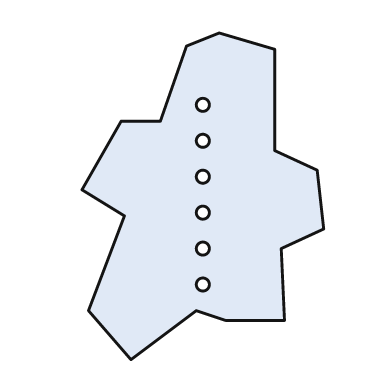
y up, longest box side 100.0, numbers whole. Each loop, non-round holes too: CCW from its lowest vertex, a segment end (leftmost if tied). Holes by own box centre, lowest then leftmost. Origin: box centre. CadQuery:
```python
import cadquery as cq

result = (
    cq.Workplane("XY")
    .moveTo(-22.0, -50.0)
    .lineTo(-2.0, -35.0)
    .lineTo(7.0, -38.0)
    .lineTo(25.0, -38.0)
    .lineTo(24.0, -16.0)
    .lineTo(37.0, -10.0)
    .lineTo(35.0, 8.0)
    .lineTo(22.0, 14.0)
    .lineTo(22.0, 45.0)
    .lineTo(5.0, 50.0)
    .lineTo(-5.0, 46.0)
    .lineTo(-13.0, 23.0)
    .lineTo(-25.0, 23.0)
    .lineTo(-37.0, 2.0)
    .lineTo(-24.0, -6.0)
    .lineTo(-35.0, -35.0)
    .close()
    .moveTo(0.0, -27.0)
    .circle(2.0)
    .moveTo(0.0, -16.0)
    .circle(2.0)
    .moveTo(0.0, -5.0)
    .circle(2.0)
    .moveTo(0.0, 6.0)
    .circle(2.0)
    .moveTo(0.0, 17.0)
    .circle(2.0)
    .moveTo(0.0, 28.0)
    .circle(2.0)
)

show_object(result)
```